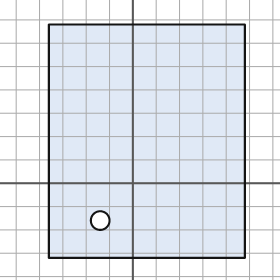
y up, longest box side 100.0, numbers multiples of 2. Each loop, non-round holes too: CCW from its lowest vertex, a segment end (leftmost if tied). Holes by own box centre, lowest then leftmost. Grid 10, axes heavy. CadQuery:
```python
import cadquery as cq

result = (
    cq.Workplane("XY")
    .moveTo(-36.0, -32.0)
    .lineTo(48.0, -32.0)
    .lineTo(48.0, 68.0)
    .lineTo(-36.0, 68.0)
    .close()
    .moveTo(-14.0, -16.0)
    .circle(4.0)
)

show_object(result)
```